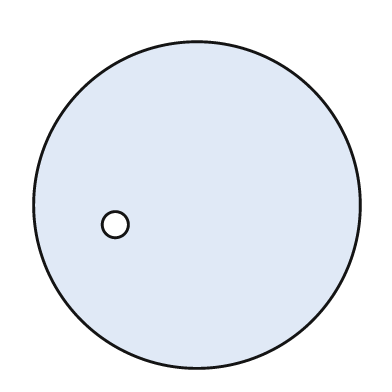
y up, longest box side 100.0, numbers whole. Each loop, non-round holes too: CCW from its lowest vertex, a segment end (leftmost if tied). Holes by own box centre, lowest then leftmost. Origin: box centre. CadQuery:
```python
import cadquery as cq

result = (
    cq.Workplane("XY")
    .moveTo(0.0, 0.0)
    .circle(50.0)
    .moveTo(-25.0, -6.0)
    .circle(4.0)
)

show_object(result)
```